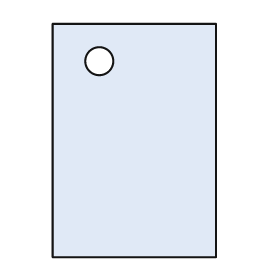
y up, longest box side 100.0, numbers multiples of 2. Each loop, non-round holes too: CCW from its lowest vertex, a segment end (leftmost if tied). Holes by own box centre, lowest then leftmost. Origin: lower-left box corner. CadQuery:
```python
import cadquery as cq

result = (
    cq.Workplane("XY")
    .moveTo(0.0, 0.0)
    .lineTo(70.0, 0.0)
    .lineTo(70.0, 100.0)
    .lineTo(0.0, 100.0)
    .close()
    .moveTo(20.0, 84.0)
    .circle(6.0)
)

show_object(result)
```